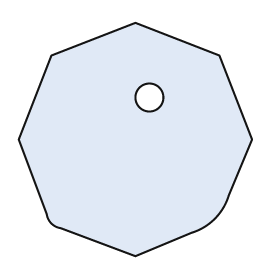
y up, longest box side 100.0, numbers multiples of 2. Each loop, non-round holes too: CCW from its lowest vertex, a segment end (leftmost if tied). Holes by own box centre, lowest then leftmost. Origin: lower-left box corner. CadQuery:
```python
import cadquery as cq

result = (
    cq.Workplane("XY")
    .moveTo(50.0, 0.0)
    .lineTo(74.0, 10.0)
    .threePointArc((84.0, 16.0), (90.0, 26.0))
    .lineTo(100.0, 50.0)
    .lineTo(86.0, 86.0)
    .lineTo(50.0, 100.0)
    .lineTo(14.0, 86.0)
    .lineTo(0.0, 50.0)
    .lineTo(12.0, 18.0)
    .threePointArc((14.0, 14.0), (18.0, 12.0))
    .close()
    .moveTo(56.0, 68.0)
    .circle(6.0)
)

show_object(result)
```